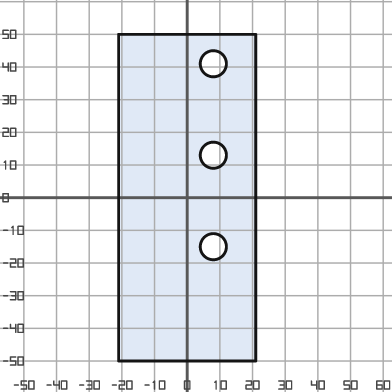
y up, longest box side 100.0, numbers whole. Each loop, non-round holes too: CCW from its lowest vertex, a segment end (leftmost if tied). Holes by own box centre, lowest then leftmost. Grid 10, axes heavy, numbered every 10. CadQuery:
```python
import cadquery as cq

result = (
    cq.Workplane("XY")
    .moveTo(-21.0, -50.0)
    .lineTo(21.0, -50.0)
    .lineTo(21.0, 50.0)
    .lineTo(-21.0, 50.0)
    .close()
    .moveTo(8.0, -15.0)
    .circle(4.0)
    .moveTo(8.0, 13.0)
    .circle(4.0)
    .moveTo(8.0, 41.0)
    .circle(4.0)
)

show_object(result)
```